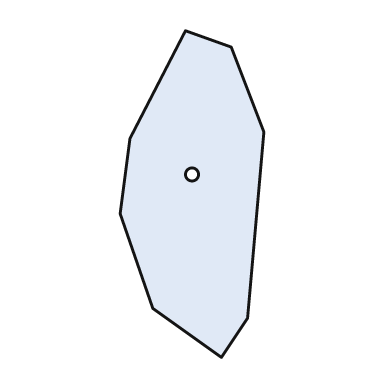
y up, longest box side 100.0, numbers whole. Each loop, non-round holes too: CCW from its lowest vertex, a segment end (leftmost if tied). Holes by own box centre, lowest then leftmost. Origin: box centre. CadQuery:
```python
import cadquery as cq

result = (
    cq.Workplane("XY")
    .moveTo(9.0, -50.0)
    .lineTo(17.0, -38.0)
    .lineTo(22.0, 19.0)
    .lineTo(12.0, 45.0)
    .lineTo(-2.0, 50.0)
    .lineTo(-19.0, 17.0)
    .lineTo(-22.0, -6.0)
    .lineTo(-12.0, -35.0)
    .close()
    .moveTo(0.0, 6.0)
    .circle(2.0)
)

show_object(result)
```